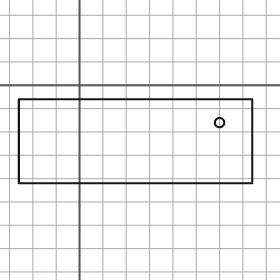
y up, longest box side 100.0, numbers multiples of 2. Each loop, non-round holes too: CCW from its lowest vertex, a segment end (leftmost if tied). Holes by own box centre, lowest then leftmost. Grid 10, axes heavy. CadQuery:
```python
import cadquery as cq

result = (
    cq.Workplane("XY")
    .moveTo(-26.0, -42.0)
    .lineTo(74.0, -42.0)
    .lineTo(74.0, -6.0)
    .lineTo(-26.0, -6.0)
    .close()
    .moveTo(60.0, -16.0)
    .circle(2.0)
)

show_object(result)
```